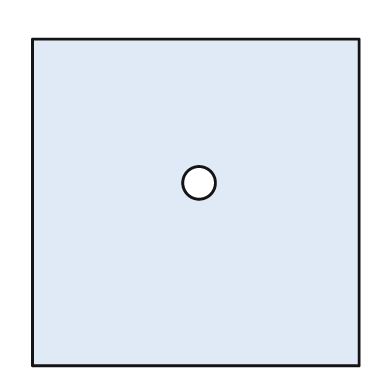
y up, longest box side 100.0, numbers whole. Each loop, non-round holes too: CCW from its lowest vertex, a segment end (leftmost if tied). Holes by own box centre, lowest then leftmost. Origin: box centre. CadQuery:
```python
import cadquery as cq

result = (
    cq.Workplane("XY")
    .moveTo(-50.0, -50.0)
    .lineTo(50.0, -50.0)
    .lineTo(50.0, 50.0)
    .lineTo(-50.0, 50.0)
    .close()
    .moveTo(1.0, 6.0)
    .circle(5.0)
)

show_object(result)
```